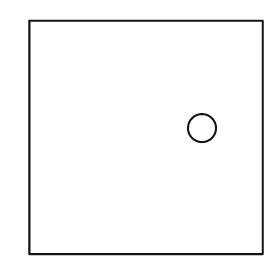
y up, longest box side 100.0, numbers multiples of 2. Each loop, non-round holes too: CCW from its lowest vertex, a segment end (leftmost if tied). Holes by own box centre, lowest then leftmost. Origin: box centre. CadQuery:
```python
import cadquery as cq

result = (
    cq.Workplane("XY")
    .moveTo(-50.0, -50.0)
    .lineTo(50.0, -50.0)
    .lineTo(50.0, 50.0)
    .lineTo(-50.0, 50.0)
    .close()
    .moveTo(24.0, 4.0)
    .circle(6.0)
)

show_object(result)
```